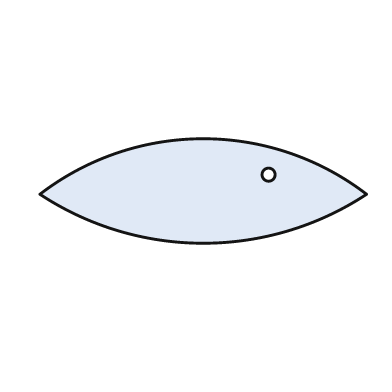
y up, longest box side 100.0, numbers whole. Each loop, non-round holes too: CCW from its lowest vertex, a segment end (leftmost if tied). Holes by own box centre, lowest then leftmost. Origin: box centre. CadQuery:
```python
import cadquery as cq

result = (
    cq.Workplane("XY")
    .moveTo(-50.0, -1.0)
    .threePointArc((0.0, -16.0), (50.0, -1.0))
    .threePointArc((0.0, 16.0), (-50.0, -1.0))
    .close()
    .moveTo(20.0, 5.0)
    .circle(2.0)
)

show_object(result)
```